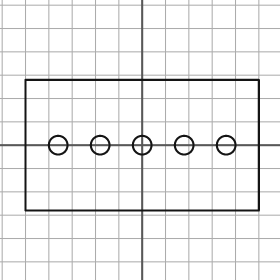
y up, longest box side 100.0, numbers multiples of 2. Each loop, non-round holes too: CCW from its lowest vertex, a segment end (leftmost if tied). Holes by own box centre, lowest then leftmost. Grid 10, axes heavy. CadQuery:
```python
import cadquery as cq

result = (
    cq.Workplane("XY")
    .moveTo(-50.0, -28.0)
    .lineTo(50.0, -28.0)
    .lineTo(50.0, 28.0)
    .lineTo(-50.0, 28.0)
    .close()
    .moveTo(-36.0, 0.0)
    .circle(4.0)
    .moveTo(-18.0, 0.0)
    .circle(4.0)
    .moveTo(0.0, 0.0)
    .circle(4.0)
    .moveTo(18.0, 0.0)
    .circle(4.0)
    .moveTo(36.0, 0.0)
    .circle(4.0)
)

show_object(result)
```